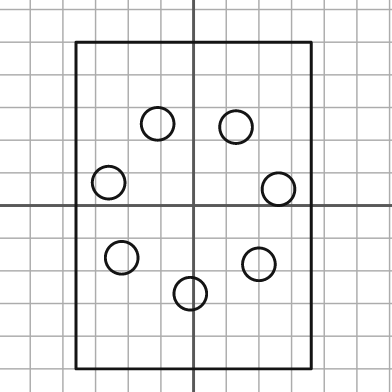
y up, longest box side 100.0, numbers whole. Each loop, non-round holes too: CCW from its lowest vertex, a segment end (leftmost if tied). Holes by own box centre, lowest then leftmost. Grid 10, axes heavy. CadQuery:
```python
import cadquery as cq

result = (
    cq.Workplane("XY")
    .moveTo(-36.0, -50.0)
    .lineTo(36.0, -50.0)
    .lineTo(36.0, 50.0)
    .lineTo(-36.0, 50.0)
    .close()
    .moveTo(-1.0, -27.0)
    .circle(5.0)
    .moveTo(20.0, -18.0)
    .circle(5.0)
    .moveTo(-22.0, -16.0)
    .circle(5.0)
    .moveTo(26.0, 5.0)
    .circle(5.0)
    .moveTo(-26.0, 7.0)
    .circle(5.0)
    .moveTo(13.0, 24.0)
    .circle(5.0)
    .moveTo(-11.0, 25.0)
    .circle(5.0)
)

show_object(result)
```